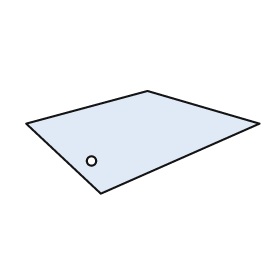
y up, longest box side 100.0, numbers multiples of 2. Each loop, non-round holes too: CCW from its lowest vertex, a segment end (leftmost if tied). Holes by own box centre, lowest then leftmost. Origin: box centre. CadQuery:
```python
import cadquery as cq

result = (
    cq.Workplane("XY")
    .moveTo(-18.0, -22.0)
    .lineTo(50.0, 8.0)
    .lineTo(2.0, 22.0)
    .lineTo(-50.0, 8.0)
    .close()
    .moveTo(-22.0, -8.0)
    .circle(2.0)
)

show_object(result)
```